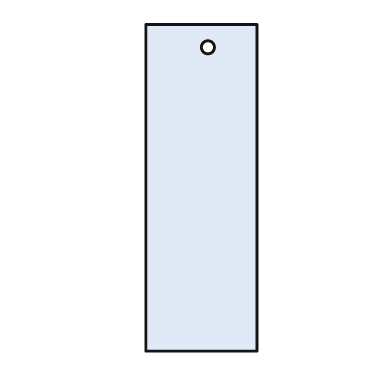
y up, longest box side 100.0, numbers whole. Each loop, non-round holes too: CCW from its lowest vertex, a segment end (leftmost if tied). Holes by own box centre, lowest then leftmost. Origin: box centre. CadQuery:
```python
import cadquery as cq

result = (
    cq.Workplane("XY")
    .moveTo(-17.0, -50.0)
    .lineTo(17.0, -50.0)
    .lineTo(17.0, 50.0)
    .lineTo(-17.0, 50.0)
    .close()
    .moveTo(2.0, 43.0)
    .circle(2.0)
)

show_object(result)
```